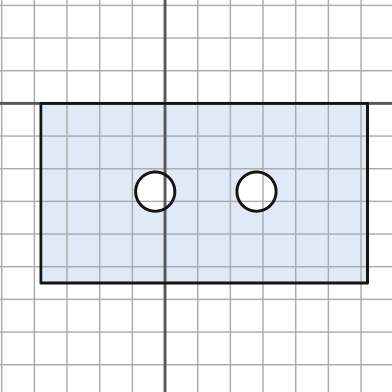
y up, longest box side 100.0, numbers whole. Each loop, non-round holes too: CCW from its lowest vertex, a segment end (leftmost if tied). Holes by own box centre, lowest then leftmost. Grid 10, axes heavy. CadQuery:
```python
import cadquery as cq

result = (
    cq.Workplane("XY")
    .moveTo(-38.0, -55.0)
    .lineTo(62.0, -55.0)
    .lineTo(62.0, 0.0)
    .lineTo(-38.0, 0.0)
    .close()
    .moveTo(-3.0, -27.0)
    .circle(6.0)
    .moveTo(28.0, -27.0)
    .circle(6.0)
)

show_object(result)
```